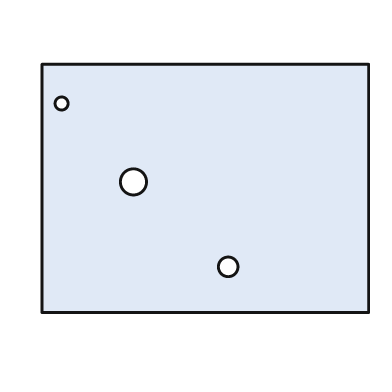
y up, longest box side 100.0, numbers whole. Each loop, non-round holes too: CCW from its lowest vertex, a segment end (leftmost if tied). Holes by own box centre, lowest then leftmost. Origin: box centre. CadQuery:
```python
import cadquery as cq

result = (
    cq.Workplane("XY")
    .moveTo(-50.0, -38.0)
    .lineTo(50.0, -38.0)
    .lineTo(50.0, 38.0)
    .lineTo(-50.0, 38.0)
    .close()
    .moveTo(7.0, -24.0)
    .circle(3.0)
    .moveTo(-22.0, 2.0)
    .circle(4.0)
    .moveTo(-44.0, 26.0)
    .circle(2.0)
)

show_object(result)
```